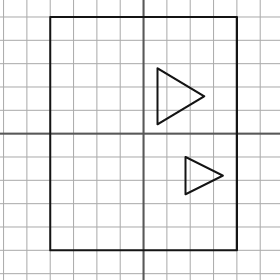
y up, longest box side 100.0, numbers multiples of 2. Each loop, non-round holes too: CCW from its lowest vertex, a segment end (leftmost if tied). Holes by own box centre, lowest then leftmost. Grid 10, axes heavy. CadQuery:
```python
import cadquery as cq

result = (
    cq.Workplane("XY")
    .moveTo(-40.0, -50.0)
    .lineTo(40.0, -50.0)
    .lineTo(40.0, 50.0)
    .lineTo(-40.0, 50.0)
    .close()
    .moveTo(18.0, -26.0)
    .lineTo(34.0, -18.0)
    .lineTo(18.0, -10.0)
    .close()
    .moveTo(6.0, 4.0)
    .lineTo(26.0, 16.0)
    .lineTo(6.0, 28.0)
    .close()
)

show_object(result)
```